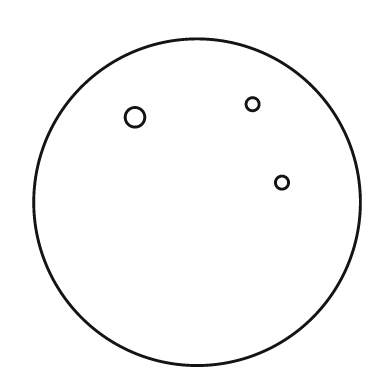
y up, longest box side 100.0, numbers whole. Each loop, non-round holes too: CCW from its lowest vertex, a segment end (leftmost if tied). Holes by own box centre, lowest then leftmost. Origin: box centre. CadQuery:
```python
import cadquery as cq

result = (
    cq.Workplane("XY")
    .moveTo(0.0, 0.0)
    .circle(50.0)
    .moveTo(26.0, 6.0)
    .circle(2.0)
    .moveTo(-19.0, 26.0)
    .circle(3.0)
    .moveTo(17.0, 30.0)
    .circle(2.0)
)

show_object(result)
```